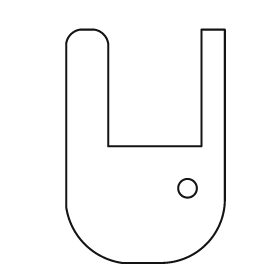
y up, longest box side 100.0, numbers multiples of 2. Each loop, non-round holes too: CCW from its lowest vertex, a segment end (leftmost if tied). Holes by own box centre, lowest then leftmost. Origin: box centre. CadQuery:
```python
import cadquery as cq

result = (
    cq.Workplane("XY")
    .moveTo(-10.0, -50.0)
    .lineTo(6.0, -50.0)
    .threePointArc((26.0, -42.0), (34.0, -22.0))
    .lineTo(34.0, 50.0)
    .lineTo(24.0, 50.0)
    .lineTo(24.0, 0.0)
    .lineTo(-16.0, 0.0)
    .lineTo(-16.0, 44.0)
    .threePointArc((-18.0, 48.0), (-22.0, 50.0))
    .lineTo(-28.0, 50.0)
    .threePointArc((-32.0, 48.0), (-34.0, 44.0))
    .lineTo(-34.0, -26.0)
    .threePointArc((-26.0, -42.0), (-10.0, -50.0))
    .close()
    .moveTo(18.0, -18.0)
    .circle(4.0)
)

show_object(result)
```